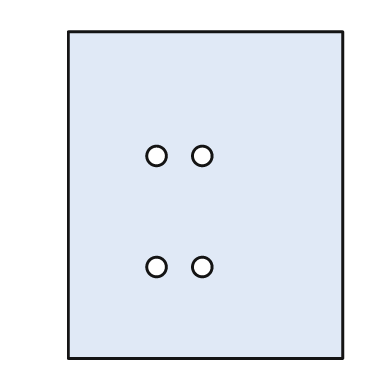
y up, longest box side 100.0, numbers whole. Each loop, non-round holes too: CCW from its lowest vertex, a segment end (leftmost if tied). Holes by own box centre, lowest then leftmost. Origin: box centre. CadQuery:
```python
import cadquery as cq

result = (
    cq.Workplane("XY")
    .moveTo(-42.0, -50.0)
    .lineTo(42.0, -50.0)
    .lineTo(42.0, 50.0)
    .lineTo(-42.0, 50.0)
    .close()
    .moveTo(-15.0, -22.0)
    .circle(3.0)
    .moveTo(-1.0, -22.0)
    .circle(3.0)
    .moveTo(-15.0, 12.0)
    .circle(3.0)
    .moveTo(-1.0, 12.0)
    .circle(3.0)
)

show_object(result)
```